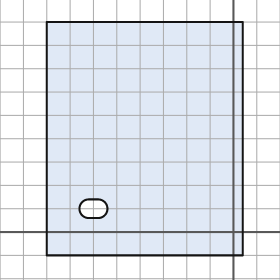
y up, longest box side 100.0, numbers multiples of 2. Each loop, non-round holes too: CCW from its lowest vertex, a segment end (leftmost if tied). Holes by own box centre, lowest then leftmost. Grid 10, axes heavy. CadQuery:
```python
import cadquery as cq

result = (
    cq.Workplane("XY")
    .moveTo(-80.0, -10.0)
    .lineTo(4.0, -10.0)
    .lineTo(4.0, 90.0)
    .lineTo(-80.0, 90.0)
    .close()
    .moveTo(-62.0, 6.0)
    .lineTo(-58.0, 6.0)
    .threePointArc((-54.0, 10.0), (-58.0, 14.0))
    .lineTo(-62.0, 14.0)
    .threePointArc((-66.0, 10.0), (-62.0, 6.0))
    .close()
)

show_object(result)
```